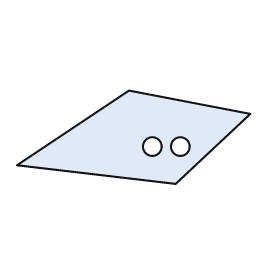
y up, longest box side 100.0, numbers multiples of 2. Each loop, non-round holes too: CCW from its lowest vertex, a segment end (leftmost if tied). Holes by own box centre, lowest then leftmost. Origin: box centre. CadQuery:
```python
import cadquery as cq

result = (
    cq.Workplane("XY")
    .moveTo(18.0, -20.0)
    .lineTo(50.0, 10.0)
    .lineTo(-2.0, 20.0)
    .lineTo(-50.0, -12.0)
    .close()
    .moveTo(8.0, -4.0)
    .circle(4.0)
    .moveTo(20.0, -4.0)
    .circle(4.0)
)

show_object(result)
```